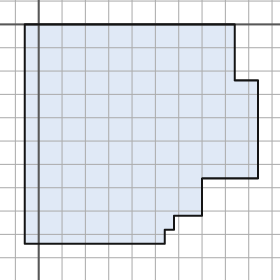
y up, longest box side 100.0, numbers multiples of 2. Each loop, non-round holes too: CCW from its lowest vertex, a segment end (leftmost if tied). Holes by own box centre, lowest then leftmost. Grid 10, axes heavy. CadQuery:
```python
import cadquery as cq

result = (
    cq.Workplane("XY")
    .moveTo(-6.0, -94.0)
    .lineTo(54.0, -94.0)
    .lineTo(54.0, -88.0)
    .lineTo(58.0, -88.0)
    .lineTo(58.0, -82.0)
    .lineTo(70.0, -82.0)
    .lineTo(70.0, -66.0)
    .lineTo(94.0, -66.0)
    .lineTo(94.0, -24.0)
    .lineTo(84.0, -24.0)
    .lineTo(84.0, 0.0)
    .lineTo(-6.0, 0.0)
    .close()
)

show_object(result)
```